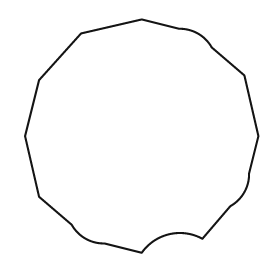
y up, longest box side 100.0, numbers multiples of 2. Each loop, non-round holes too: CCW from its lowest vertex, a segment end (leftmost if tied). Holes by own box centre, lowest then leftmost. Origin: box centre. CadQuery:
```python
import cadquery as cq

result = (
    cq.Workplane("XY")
    .moveTo(0.0, -50.0)
    .threePointArc((12.0, -42.0), (26.0, -44.0))
    .lineTo(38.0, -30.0)
    .threePointArc((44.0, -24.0), (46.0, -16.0))
    .lineTo(50.0, 0.0)
    .lineTo(44.0, 26.0)
    .lineTo(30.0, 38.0)
    .threePointArc((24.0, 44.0), (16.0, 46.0))
    .lineTo(0.0, 50.0)
    .lineTo(-26.0, 44.0)
    .lineTo(-44.0, 24.0)
    .lineTo(-50.0, 0.0)
    .lineTo(-44.0, -26.0)
    .lineTo(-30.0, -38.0)
    .threePointArc((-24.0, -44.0), (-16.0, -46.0))
    .close()
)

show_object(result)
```